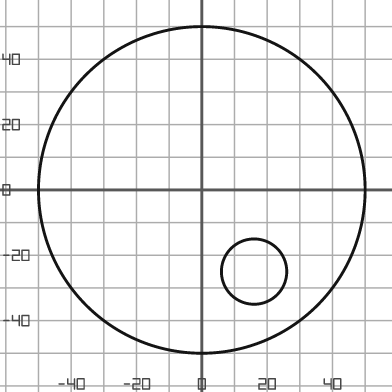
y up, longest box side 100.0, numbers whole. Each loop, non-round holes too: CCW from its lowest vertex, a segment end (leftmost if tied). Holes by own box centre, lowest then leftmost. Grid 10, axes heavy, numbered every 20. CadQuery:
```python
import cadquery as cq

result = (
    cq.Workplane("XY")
    .moveTo(0.0, 0.0)
    .circle(50.0)
    .moveTo(16.0, -25.0)
    .circle(10.0)
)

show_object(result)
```